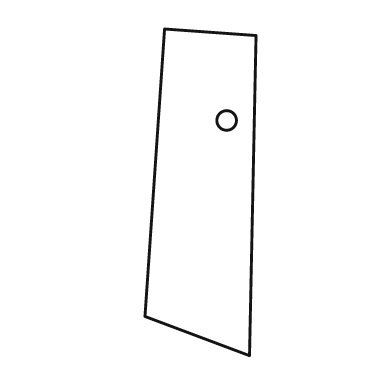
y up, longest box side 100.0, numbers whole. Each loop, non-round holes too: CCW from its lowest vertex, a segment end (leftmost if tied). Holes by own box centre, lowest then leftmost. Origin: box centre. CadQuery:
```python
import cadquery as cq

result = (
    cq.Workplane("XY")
    .moveTo(15.0, -50.0)
    .lineTo(17.0, 48.0)
    .lineTo(-11.0, 50.0)
    .lineTo(-17.0, -38.0)
    .close()
    .moveTo(8.0, 22.0)
    .circle(3.0)
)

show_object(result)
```